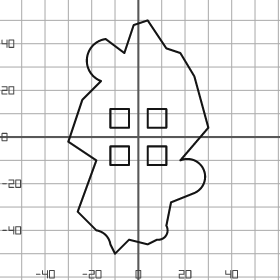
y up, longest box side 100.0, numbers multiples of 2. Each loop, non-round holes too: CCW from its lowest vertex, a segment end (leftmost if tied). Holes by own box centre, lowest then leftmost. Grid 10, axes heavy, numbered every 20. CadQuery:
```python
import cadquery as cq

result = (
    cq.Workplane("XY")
    .moveTo(-10.0, -50.0)
    .lineTo(-4.0, -44.0)
    .lineTo(4.0, -46.0)
    .lineTo(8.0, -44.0)
    .threePointArc((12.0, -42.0), (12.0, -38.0))
    .lineTo(14.0, -28.0)
    .lineTo(24.0, -24.0)
    .threePointArc((28.0, -14.0), (18.0, -10.0))
    .lineTo(30.0, 4.0)
    .lineTo(24.0, 26.0)
    .lineTo(18.0, 36.0)
    .lineTo(12.0, 38.0)
    .lineTo(4.0, 50.0)
    .lineTo(-2.0, 48.0)
    .lineTo(-6.0, 36.0)
    .lineTo(-14.0, 42.0)
    .threePointArc((-22.0, 34.0), (-16.0, 24.0))
    .lineTo(-24.0, 16.0)
    .lineTo(-30.0, -2.0)
    .lineTo(-18.0, -10.0)
    .lineTo(-26.0, -32.0)
    .lineTo(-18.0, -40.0)
    .threePointArc((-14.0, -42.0), (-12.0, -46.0))
    .close()
    .moveTo(-12.0, -12.0)
    .lineTo(-4.0, -12.0)
    .lineTo(-4.0, -4.0)
    .lineTo(-12.0, -4.0)
    .close()
    .moveTo(4.0, -12.0)
    .lineTo(12.0, -12.0)
    .lineTo(12.0, -4.0)
    .lineTo(4.0, -4.0)
    .close()
    .moveTo(-12.0, 4.0)
    .lineTo(-4.0, 4.0)
    .lineTo(-4.0, 12.0)
    .lineTo(-12.0, 12.0)
    .close()
    .moveTo(4.0, 4.0)
    .lineTo(12.0, 4.0)
    .lineTo(12.0, 12.0)
    .lineTo(4.0, 12.0)
    .close()
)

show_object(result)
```